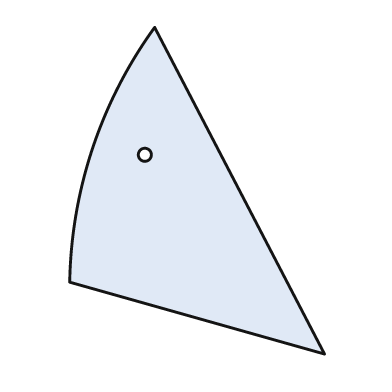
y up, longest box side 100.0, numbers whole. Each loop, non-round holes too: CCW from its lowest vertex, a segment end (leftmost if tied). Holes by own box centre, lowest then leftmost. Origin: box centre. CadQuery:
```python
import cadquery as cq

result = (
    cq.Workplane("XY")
    .moveTo(39.0, -50.0)
    .lineTo(-13.0, 50.0)
    .threePointArc((-32.0, 13.0), (-39.0, -28.0))
    .close()
    .moveTo(-16.0, 11.0)
    .circle(2.0)
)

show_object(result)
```